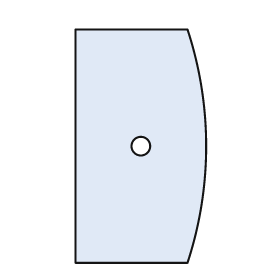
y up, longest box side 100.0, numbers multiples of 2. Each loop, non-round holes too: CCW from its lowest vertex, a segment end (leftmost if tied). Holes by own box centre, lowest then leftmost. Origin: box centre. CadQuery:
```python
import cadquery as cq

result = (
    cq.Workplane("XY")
    .moveTo(-28.0, -50.0)
    .lineTo(20.0, -50.0)
    .threePointArc((28.0, 0.0), (20.0, 50.0))
    .lineTo(-28.0, 50.0)
    .close()
    .moveTo(0.0, 0.0)
    .circle(4.0)
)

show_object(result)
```